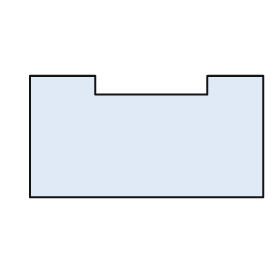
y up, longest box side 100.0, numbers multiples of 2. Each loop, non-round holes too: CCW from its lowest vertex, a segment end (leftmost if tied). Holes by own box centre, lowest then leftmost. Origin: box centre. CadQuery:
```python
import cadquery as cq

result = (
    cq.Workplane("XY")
    .moveTo(-50.0, -26.0)
    .lineTo(50.0, -26.0)
    .lineTo(50.0, 26.0)
    .lineTo(26.0, 26.0)
    .lineTo(26.0, 18.0)
    .lineTo(-22.0, 18.0)
    .lineTo(-22.0, 26.0)
    .lineTo(-50.0, 26.0)
    .close()
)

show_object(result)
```